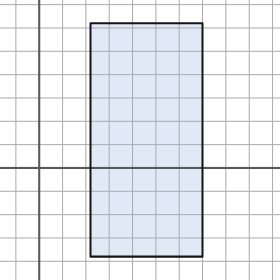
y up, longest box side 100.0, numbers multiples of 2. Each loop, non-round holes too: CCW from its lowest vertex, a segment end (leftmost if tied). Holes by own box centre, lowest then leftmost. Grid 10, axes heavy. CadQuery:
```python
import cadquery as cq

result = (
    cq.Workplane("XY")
    .moveTo(22.0, -38.0)
    .lineTo(70.0, -38.0)
    .lineTo(70.0, 62.0)
    .lineTo(22.0, 62.0)
    .close()
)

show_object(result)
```